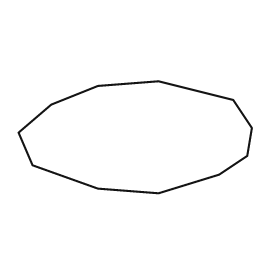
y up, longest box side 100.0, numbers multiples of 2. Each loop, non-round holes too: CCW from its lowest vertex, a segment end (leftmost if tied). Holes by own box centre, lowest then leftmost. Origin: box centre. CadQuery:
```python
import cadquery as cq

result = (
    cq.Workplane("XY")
    .moveTo(10.0, -24.0)
    .lineTo(36.0, -16.0)
    .lineTo(48.0, -8.0)
    .lineTo(50.0, 4.0)
    .lineTo(42.0, 16.0)
    .lineTo(10.0, 24.0)
    .lineTo(-16.0, 22.0)
    .lineTo(-36.0, 14.0)
    .lineTo(-50.0, 2.0)
    .lineTo(-44.0, -12.0)
    .lineTo(-16.0, -22.0)
    .close()
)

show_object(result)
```